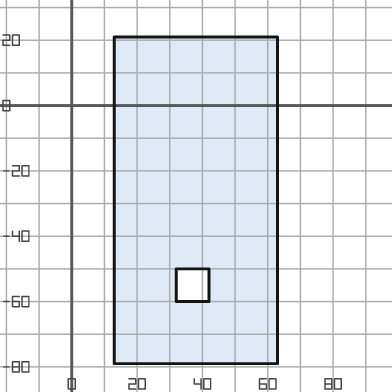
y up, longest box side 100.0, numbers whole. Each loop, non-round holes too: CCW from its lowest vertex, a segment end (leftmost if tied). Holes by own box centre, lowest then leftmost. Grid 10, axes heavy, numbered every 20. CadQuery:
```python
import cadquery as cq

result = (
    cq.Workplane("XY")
    .moveTo(13.0, -79.0)
    .lineTo(63.0, -79.0)
    .lineTo(63.0, 21.0)
    .lineTo(13.0, 21.0)
    .close()
    .moveTo(32.0, -60.0)
    .lineTo(42.0, -60.0)
    .lineTo(42.0, -50.0)
    .lineTo(32.0, -50.0)
    .close()
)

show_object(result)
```